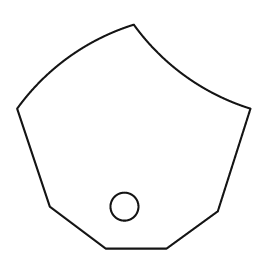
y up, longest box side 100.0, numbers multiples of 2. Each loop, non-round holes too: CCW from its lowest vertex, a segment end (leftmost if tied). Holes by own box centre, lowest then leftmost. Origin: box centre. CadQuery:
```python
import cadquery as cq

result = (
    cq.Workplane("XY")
    .moveTo(-12.0, -48.0)
    .lineTo(14.0, -48.0)
    .lineTo(36.0, -32.0)
    .lineTo(50.0, 12.0)
    .threePointArc((22.0, 26.0), (0.0, 48.0))
    .threePointArc((-28.0, 34.0), (-50.0, 12.0))
    .lineTo(-36.0, -30.0)
    .close()
    .moveTo(-4.0, -30.0)
    .circle(6.0)
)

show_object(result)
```